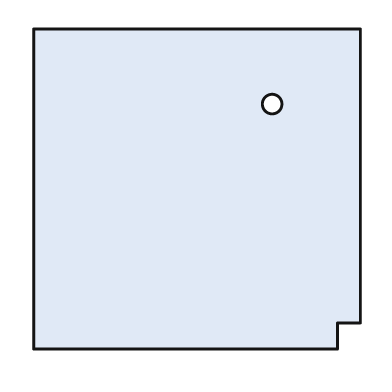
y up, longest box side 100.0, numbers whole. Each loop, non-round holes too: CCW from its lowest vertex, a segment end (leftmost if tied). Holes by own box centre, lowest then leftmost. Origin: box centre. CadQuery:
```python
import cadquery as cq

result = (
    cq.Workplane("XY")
    .moveTo(-50.0, -49.0)
    .lineTo(43.0, -49.0)
    .lineTo(43.0, -41.0)
    .lineTo(50.0, -41.0)
    .lineTo(50.0, 49.0)
    .lineTo(-50.0, 49.0)
    .close()
    .moveTo(23.0, 26.0)
    .circle(3.0)
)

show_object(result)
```